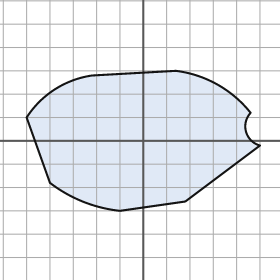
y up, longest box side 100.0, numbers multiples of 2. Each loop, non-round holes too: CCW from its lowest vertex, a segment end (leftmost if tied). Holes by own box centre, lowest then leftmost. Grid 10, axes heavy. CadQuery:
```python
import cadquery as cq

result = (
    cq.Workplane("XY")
    .moveTo(-10.0, -30.0)
    .lineTo(18.0, -26.0)
    .lineTo(50.0, -2.0)
    .threePointArc((44.0, 4.0), (46.0, 12.0))
    .threePointArc((32.0, 24.0), (14.0, 30.0))
    .lineTo(-22.0, 28.0)
    .threePointArc((-38.0, 22.0), (-50.0, 10.0))
    .lineTo(-40.0, -18.0)
    .threePointArc((-26.0, -26.0), (-10.0, -30.0))
    .close()
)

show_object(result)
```